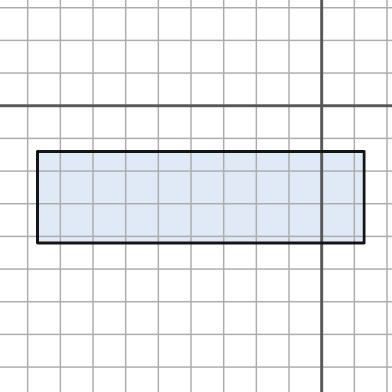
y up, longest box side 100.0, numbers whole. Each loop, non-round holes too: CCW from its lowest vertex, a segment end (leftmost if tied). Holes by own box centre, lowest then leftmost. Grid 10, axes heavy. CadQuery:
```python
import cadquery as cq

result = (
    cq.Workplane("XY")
    .moveTo(-87.0, -42.0)
    .lineTo(13.0, -42.0)
    .lineTo(13.0, -14.0)
    .lineTo(-87.0, -14.0)
    .close()
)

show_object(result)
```